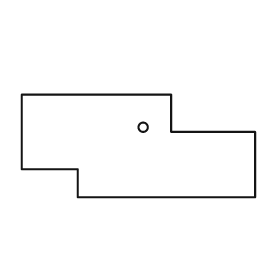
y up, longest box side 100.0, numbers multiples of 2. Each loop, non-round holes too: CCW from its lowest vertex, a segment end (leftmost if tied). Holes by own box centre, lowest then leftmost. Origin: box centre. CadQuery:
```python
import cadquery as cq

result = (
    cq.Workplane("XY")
    .moveTo(-26.0, -22.0)
    .lineTo(50.0, -22.0)
    .lineTo(50.0, 6.0)
    .lineTo(14.0, 6.0)
    .lineTo(14.0, 22.0)
    .lineTo(-50.0, 22.0)
    .lineTo(-50.0, -10.0)
    .lineTo(-26.0, -10.0)
    .close()
    .moveTo(2.0, 8.0)
    .circle(2.0)
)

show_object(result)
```